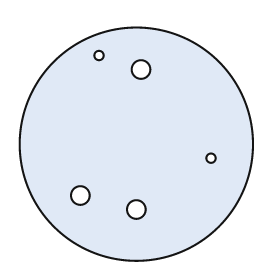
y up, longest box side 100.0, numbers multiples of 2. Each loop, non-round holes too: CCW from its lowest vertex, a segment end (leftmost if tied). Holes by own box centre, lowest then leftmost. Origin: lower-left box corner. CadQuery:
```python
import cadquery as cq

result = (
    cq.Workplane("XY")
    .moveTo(50.0, 50.0)
    .circle(50.0)
    .moveTo(50.0, 22.0)
    .circle(4.0)
    .moveTo(26.0, 28.0)
    .circle(4.0)
    .moveTo(82.0, 44.0)
    .circle(2.0)
    .moveTo(52.0, 82.0)
    .circle(4.0)
    .moveTo(34.0, 88.0)
    .circle(2.0)
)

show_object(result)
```